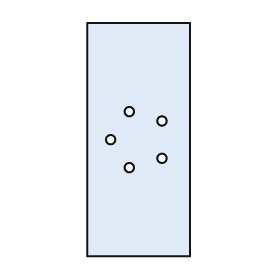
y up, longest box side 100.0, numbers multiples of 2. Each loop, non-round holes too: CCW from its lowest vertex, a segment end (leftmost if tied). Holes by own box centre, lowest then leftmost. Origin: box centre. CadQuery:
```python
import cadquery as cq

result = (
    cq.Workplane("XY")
    .moveTo(-22.0, -50.0)
    .lineTo(22.0, -50.0)
    .lineTo(22.0, 50.0)
    .lineTo(-22.0, 50.0)
    .close()
    .moveTo(-4.0, -12.0)
    .circle(2.0)
    .moveTo(10.0, -8.0)
    .circle(2.0)
    .moveTo(-12.0, 0.0)
    .circle(2.0)
    .moveTo(10.0, 8.0)
    .circle(2.0)
    .moveTo(-4.0, 12.0)
    .circle(2.0)
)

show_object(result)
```